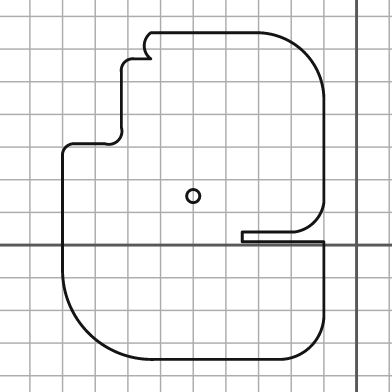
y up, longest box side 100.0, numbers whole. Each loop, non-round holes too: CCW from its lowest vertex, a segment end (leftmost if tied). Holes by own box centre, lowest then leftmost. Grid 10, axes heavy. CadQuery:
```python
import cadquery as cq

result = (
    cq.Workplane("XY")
    .moveTo(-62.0, -35.0)
    .lineTo(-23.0, -35.0)
    .threePointArc((-14.0, -31.0), (-10.0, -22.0))
    .lineTo(-10.0, 1.0)
    .lineTo(-35.0, 1.0)
    .lineTo(-35.0, 4.0)
    .lineTo(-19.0, 4.0)
    .threePointArc((-13.0, 7.0), (-10.0, 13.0))
    .lineTo(-10.0, 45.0)
    .threePointArc((-16.0, 59.0), (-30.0, 65.0))
    .lineTo(-63.0, 65.0)
    .threePointArc((-65.0, 61.0), (-63.0, 57.0))
    .lineTo(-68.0, 57.0)
    .threePointArc((-71.0, 56.0), (-72.0, 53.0))
    .lineTo(-72.0, 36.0)
    .threePointArc((-73.0, 32.0), (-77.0, 31.0))
    .lineTo(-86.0, 31.0)
    .threePointArc((-89.0, 30.0), (-90.0, 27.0))
    .lineTo(-90.0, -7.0)
    .threePointArc((-82.0, -27.0), (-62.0, -35.0))
    .close()
    .moveTo(-50.0, 15.0)
    .circle(2.0)
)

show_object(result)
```